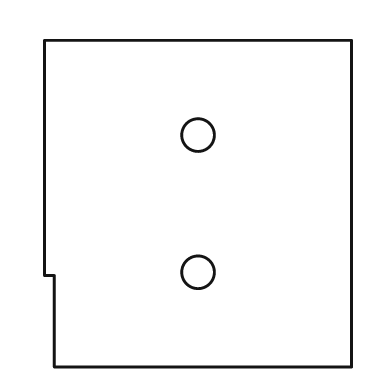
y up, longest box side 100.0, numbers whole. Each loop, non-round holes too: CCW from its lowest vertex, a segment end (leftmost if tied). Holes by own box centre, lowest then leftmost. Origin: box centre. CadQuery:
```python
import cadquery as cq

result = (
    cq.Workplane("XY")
    .moveTo(-44.0, -50.0)
    .lineTo(47.0, -50.0)
    .lineTo(47.0, 50.0)
    .lineTo(-47.0, 50.0)
    .lineTo(-47.0, -22.0)
    .lineTo(-44.0, -22.0)
    .close()
    .moveTo(0.0, -21.0)
    .circle(5.0)
    .moveTo(0.0, 21.0)
    .circle(5.0)
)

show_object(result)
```